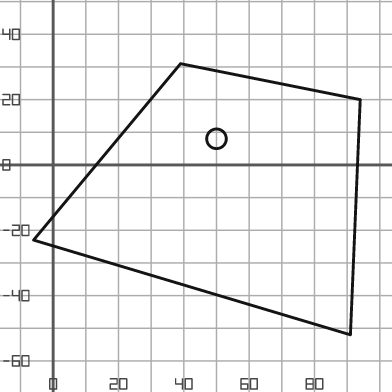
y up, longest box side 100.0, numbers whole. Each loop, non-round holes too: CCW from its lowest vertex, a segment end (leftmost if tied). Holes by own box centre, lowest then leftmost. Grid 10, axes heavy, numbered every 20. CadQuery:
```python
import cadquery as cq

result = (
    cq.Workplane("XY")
    .moveTo(91.0, -52.0)
    .lineTo(94.0, 20.0)
    .lineTo(39.0, 31.0)
    .lineTo(-6.0, -23.0)
    .close()
    .moveTo(50.0, 8.0)
    .circle(3.0)
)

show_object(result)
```